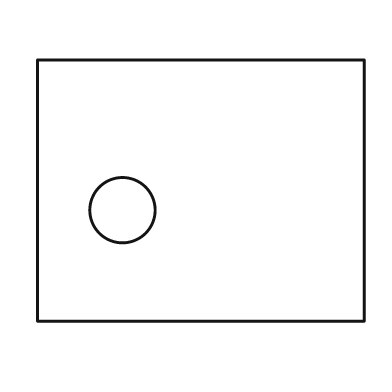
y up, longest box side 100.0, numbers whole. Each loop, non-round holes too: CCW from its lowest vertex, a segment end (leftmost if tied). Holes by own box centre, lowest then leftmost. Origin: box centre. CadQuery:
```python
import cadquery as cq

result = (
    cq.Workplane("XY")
    .moveTo(-50.0, -40.0)
    .lineTo(50.0, -40.0)
    .lineTo(50.0, 40.0)
    .lineTo(-50.0, 40.0)
    .close()
    .moveTo(-24.0, -6.0)
    .circle(10.0)
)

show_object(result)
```